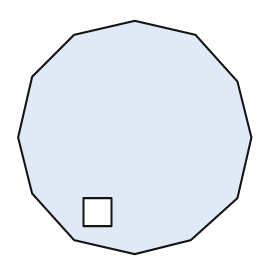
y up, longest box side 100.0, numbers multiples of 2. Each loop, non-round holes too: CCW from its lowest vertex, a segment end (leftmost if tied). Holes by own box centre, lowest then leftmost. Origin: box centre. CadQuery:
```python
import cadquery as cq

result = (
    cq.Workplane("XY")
    .moveTo(0.0, -50.0)
    .lineTo(24.0, -44.0)
    .lineTo(44.0, -26.0)
    .lineTo(50.0, 0.0)
    .lineTo(44.0, 24.0)
    .lineTo(26.0, 44.0)
    .lineTo(0.0, 50.0)
    .lineTo(-26.0, 44.0)
    .lineTo(-44.0, 26.0)
    .lineTo(-50.0, 0.0)
    .lineTo(-44.0, -24.0)
    .lineTo(-26.0, -44.0)
    .close()
    .moveTo(-22.0, -38.0)
    .lineTo(-10.0, -38.0)
    .lineTo(-10.0, -26.0)
    .lineTo(-22.0, -26.0)
    .close()
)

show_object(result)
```